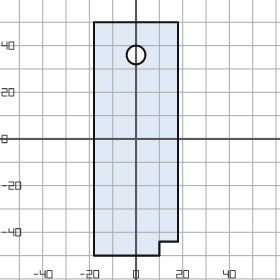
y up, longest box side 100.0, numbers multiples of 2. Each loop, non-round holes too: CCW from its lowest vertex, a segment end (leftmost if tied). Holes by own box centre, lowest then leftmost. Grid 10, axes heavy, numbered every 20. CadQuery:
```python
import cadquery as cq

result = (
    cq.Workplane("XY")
    .moveTo(-18.0, -50.0)
    .lineTo(10.0, -50.0)
    .lineTo(10.0, -44.0)
    .lineTo(18.0, -44.0)
    .lineTo(18.0, 50.0)
    .lineTo(-18.0, 50.0)
    .close()
    .moveTo(0.0, 36.0)
    .circle(4.0)
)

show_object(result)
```